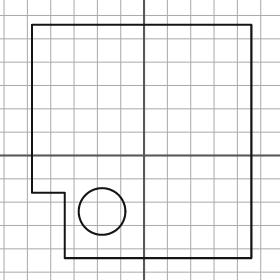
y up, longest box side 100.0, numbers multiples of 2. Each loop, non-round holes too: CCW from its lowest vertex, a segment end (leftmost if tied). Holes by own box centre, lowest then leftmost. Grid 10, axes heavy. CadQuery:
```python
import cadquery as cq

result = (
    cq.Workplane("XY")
    .moveTo(-34.0, -44.0)
    .lineTo(46.0, -44.0)
    .lineTo(46.0, 56.0)
    .lineTo(-48.0, 56.0)
    .lineTo(-48.0, -16.0)
    .lineTo(-34.0, -16.0)
    .close()
    .moveTo(-18.0, -24.0)
    .circle(10.0)
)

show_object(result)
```